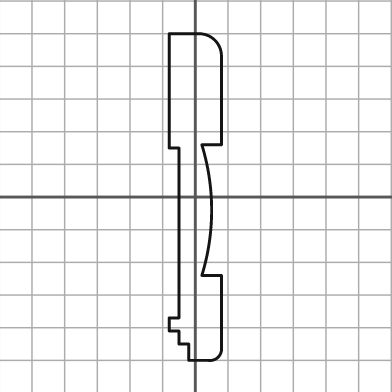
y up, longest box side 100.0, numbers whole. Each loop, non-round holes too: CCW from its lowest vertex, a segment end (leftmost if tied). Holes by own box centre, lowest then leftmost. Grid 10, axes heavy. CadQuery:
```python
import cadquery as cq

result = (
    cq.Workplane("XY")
    .moveTo(-2.0, -50.0)
    .lineTo(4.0, -50.0)
    .threePointArc((7.0, -49.0), (8.0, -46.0))
    .lineTo(8.0, -24.0)
    .lineTo(2.0, -24.0)
    .threePointArc((5.0, -4.0), (2.0, 16.0))
    .lineTo(8.0, 16.0)
    .lineTo(8.0, 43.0)
    .threePointArc((6.0, 48.0), (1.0, 50.0))
    .lineTo(-8.0, 50.0)
    .lineTo(-8.0, 15.0)
    .lineTo(-5.0, 15.0)
    .lineTo(-5.0, -37.0)
    .lineTo(-8.0, -37.0)
    .lineTo(-8.0, -41.0)
    .lineTo(-5.0, -41.0)
    .lineTo(-5.0, -45.0)
    .lineTo(-2.0, -45.0)
    .close()
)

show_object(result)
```